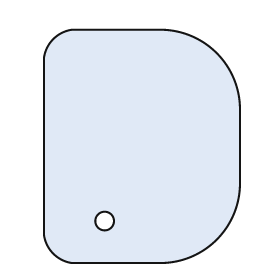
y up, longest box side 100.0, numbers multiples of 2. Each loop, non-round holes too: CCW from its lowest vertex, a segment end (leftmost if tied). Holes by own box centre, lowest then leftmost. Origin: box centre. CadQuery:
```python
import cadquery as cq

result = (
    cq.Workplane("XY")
    .moveTo(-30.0, -50.0)
    .lineTo(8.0, -50.0)
    .threePointArc((32.0, -40.0), (42.0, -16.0))
    .lineTo(42.0, 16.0)
    .threePointArc((32.0, 40.0), (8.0, 50.0))
    .lineTo(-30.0, 50.0)
    .threePointArc((-38.0, 46.0), (-42.0, 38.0))
    .lineTo(-42.0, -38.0)
    .threePointArc((-38.0, -46.0), (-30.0, -50.0))
    .close()
    .moveTo(-16.0, -32.0)
    .circle(4.0)
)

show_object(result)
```